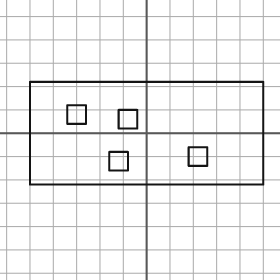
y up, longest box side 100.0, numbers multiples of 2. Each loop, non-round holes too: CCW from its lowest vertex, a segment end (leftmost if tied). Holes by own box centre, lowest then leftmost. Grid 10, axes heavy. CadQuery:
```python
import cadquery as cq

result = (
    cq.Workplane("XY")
    .moveTo(-50.0, -22.0)
    .lineTo(50.0, -22.0)
    .lineTo(50.0, 22.0)
    .lineTo(-50.0, 22.0)
    .close()
    .moveTo(-16.0, -16.0)
    .lineTo(-8.0, -16.0)
    .lineTo(-8.0, -8.0)
    .lineTo(-16.0, -8.0)
    .close()
    .moveTo(18.0, -14.0)
    .lineTo(26.0, -14.0)
    .lineTo(26.0, -6.0)
    .lineTo(18.0, -6.0)
    .close()
    .moveTo(-12.0, 2.0)
    .lineTo(-4.0, 2.0)
    .lineTo(-4.0, 10.0)
    .lineTo(-12.0, 10.0)
    .close()
    .moveTo(-34.0, 4.0)
    .lineTo(-26.0, 4.0)
    .lineTo(-26.0, 12.0)
    .lineTo(-34.0, 12.0)
    .close()
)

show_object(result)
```